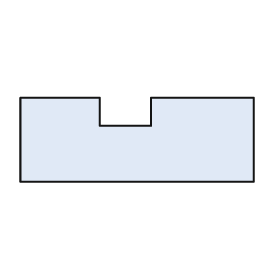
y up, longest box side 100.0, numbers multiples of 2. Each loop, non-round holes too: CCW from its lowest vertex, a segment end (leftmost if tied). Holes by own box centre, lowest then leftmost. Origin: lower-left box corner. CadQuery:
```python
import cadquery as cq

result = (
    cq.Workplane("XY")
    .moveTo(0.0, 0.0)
    .lineTo(100.0, 0.0)
    .lineTo(100.0, 36.0)
    .lineTo(56.0, 36.0)
    .lineTo(56.0, 24.0)
    .lineTo(34.0, 24.0)
    .lineTo(34.0, 36.0)
    .lineTo(0.0, 36.0)
    .close()
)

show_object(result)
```